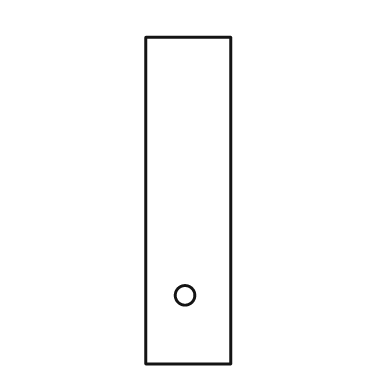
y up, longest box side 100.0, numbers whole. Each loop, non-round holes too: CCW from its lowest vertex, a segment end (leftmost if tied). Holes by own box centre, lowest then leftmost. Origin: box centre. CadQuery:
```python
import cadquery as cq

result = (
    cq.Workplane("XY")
    .moveTo(-13.0, -50.0)
    .lineTo(13.0, -50.0)
    .lineTo(13.0, 50.0)
    .lineTo(-13.0, 50.0)
    .close()
    .moveTo(-1.0, -29.0)
    .circle(3.0)
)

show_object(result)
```